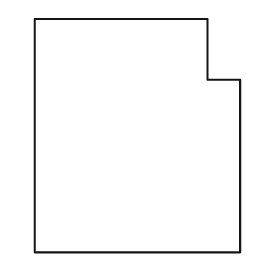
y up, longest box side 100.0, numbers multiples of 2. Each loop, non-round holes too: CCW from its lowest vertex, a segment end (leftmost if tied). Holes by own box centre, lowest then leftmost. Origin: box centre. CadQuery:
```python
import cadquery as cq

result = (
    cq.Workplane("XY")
    .moveTo(-44.0, -50.0)
    .lineTo(44.0, -50.0)
    .lineTo(44.0, 24.0)
    .lineTo(30.0, 24.0)
    .lineTo(30.0, 50.0)
    .lineTo(-44.0, 50.0)
    .close()
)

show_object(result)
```